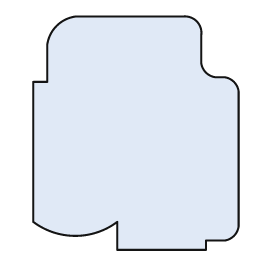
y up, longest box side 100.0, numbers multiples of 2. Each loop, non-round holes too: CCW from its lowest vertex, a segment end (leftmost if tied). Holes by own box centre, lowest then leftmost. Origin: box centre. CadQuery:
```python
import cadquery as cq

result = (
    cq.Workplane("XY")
    .moveTo(-8.0, -50.0)
    .lineTo(30.0, -50.0)
    .lineTo(30.0, -46.0)
    .lineTo(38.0, -46.0)
    .threePointArc((42.0, -44.0), (44.0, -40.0))
    .lineTo(44.0, 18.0)
    .threePointArc((42.0, 22.0), (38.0, 24.0))
    .lineTo(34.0, 24.0)
    .threePointArc((30.0, 26.0), (28.0, 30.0))
    .lineTo(28.0, 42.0)
    .threePointArc((26.0, 48.0), (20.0, 50.0))
    .lineTo(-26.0, 50.0)
    .threePointArc((-34.0, 46.0), (-38.0, 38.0))
    .lineTo(-38.0, 22.0)
    .lineTo(-44.0, 22.0)
    .lineTo(-44.0, -38.0)
    .threePointArc((-26.0, -44.0), (-8.0, -38.0))
    .close()
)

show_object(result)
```